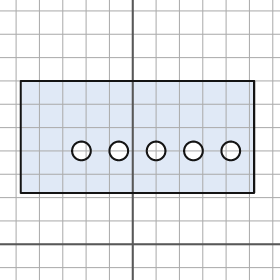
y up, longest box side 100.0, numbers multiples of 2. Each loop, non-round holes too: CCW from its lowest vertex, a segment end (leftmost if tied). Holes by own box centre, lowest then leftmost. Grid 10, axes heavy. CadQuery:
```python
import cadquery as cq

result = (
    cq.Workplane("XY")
    .moveTo(-48.0, 22.0)
    .lineTo(52.0, 22.0)
    .lineTo(52.0, 70.0)
    .lineTo(-48.0, 70.0)
    .close()
    .moveTo(-22.0, 40.0)
    .circle(4.0)
    .moveTo(-6.0, 40.0)
    .circle(4.0)
    .moveTo(10.0, 40.0)
    .circle(4.0)
    .moveTo(26.0, 40.0)
    .circle(4.0)
    .moveTo(42.0, 40.0)
    .circle(4.0)
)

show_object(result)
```